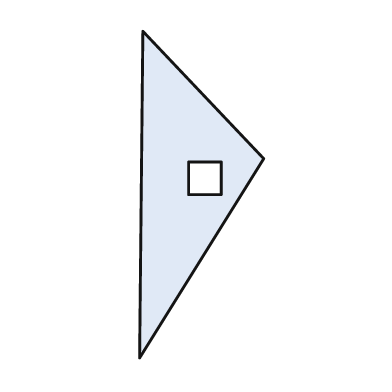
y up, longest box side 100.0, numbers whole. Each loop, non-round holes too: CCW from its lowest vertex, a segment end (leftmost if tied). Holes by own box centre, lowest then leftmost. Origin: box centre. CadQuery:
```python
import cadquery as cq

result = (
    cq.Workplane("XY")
    .moveTo(-19.0, -50.0)
    .lineTo(19.0, 11.0)
    .lineTo(-18.0, 50.0)
    .close()
    .moveTo(-4.0, 0.0)
    .lineTo(6.0, 0.0)
    .lineTo(6.0, 10.0)
    .lineTo(-4.0, 10.0)
    .close()
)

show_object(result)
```